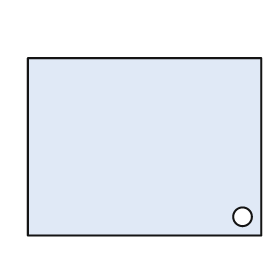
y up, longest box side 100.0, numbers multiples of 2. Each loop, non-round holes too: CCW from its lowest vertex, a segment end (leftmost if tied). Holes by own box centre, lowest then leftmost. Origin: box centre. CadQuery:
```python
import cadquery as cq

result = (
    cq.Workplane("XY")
    .moveTo(-50.0, -38.0)
    .lineTo(50.0, -38.0)
    .lineTo(50.0, 38.0)
    .lineTo(-50.0, 38.0)
    .close()
    .moveTo(42.0, -30.0)
    .circle(4.0)
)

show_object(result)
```